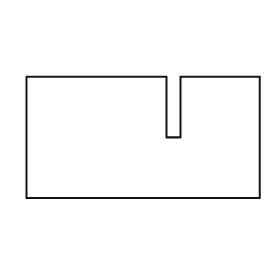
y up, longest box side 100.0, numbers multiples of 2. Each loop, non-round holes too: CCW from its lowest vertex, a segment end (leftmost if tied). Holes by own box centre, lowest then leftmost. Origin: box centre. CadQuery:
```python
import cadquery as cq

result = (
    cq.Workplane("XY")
    .moveTo(-50.0, -26.0)
    .lineTo(50.0, -26.0)
    .lineTo(50.0, 26.0)
    .lineTo(16.0, 26.0)
    .lineTo(16.0, 0.0)
    .lineTo(10.0, 0.0)
    .lineTo(10.0, 26.0)
    .lineTo(-50.0, 26.0)
    .close()
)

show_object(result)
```